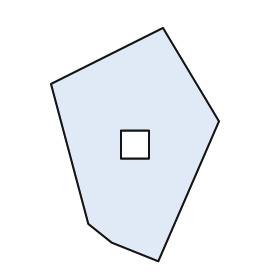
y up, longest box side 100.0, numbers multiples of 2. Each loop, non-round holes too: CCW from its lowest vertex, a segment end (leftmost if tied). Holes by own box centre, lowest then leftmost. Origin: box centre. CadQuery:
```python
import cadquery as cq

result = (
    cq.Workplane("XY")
    .moveTo(10.0, -50.0)
    .lineTo(36.0, 10.0)
    .lineTo(12.0, 50.0)
    .lineTo(-36.0, 26.0)
    .lineTo(-20.0, -34.0)
    .lineTo(-10.0, -42.0)
    .close()
    .moveTo(-6.0, -6.0)
    .lineTo(6.0, -6.0)
    .lineTo(6.0, 6.0)
    .lineTo(-6.0, 6.0)
    .close()
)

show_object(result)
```